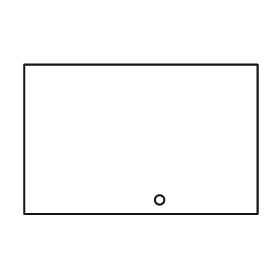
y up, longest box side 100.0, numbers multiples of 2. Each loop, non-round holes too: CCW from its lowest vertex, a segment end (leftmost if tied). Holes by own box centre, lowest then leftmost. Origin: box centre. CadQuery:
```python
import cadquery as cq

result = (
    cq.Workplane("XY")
    .moveTo(-50.0, -32.0)
    .lineTo(50.0, -32.0)
    .lineTo(50.0, 32.0)
    .lineTo(-50.0, 32.0)
    .close()
    .moveTo(8.0, -26.0)
    .circle(2.0)
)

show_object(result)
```